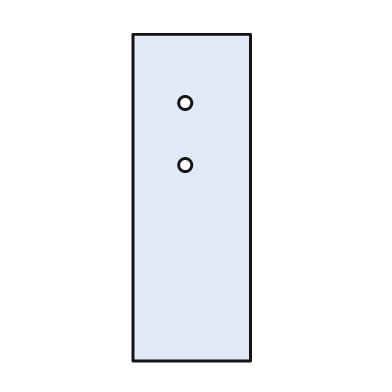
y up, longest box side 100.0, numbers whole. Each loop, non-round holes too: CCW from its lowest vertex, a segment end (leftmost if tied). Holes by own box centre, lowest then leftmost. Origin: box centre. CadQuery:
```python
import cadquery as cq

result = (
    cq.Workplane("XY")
    .moveTo(-18.0, -50.0)
    .lineTo(18.0, -50.0)
    .lineTo(18.0, 50.0)
    .lineTo(-18.0, 50.0)
    .close()
    .moveTo(-2.0, 10.0)
    .circle(2.0)
    .moveTo(-2.0, 29.0)
    .circle(2.0)
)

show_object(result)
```